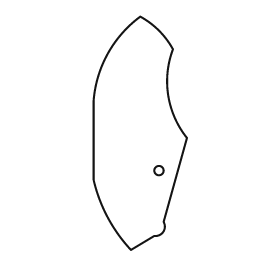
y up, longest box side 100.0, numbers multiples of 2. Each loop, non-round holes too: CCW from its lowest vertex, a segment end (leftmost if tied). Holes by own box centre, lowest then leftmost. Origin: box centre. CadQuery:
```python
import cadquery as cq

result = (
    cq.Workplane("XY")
    .moveTo(-4.0, -50.0)
    .lineTo(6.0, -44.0)
    .threePointArc((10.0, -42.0), (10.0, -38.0))
    .lineTo(20.0, -2.0)
    .threePointArc((12.0, 16.0), (14.0, 36.0))
    .threePointArc((8.0, 44.0), (0.0, 50.0))
    .threePointArc((-14.0, 34.0), (-20.0, 14.0))
    .lineTo(-20.0, -20.0)
    .threePointArc((-14.0, -36.0), (-4.0, -50.0))
    .close()
    .moveTo(8.0, -16.0)
    .circle(2.0)
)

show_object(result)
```